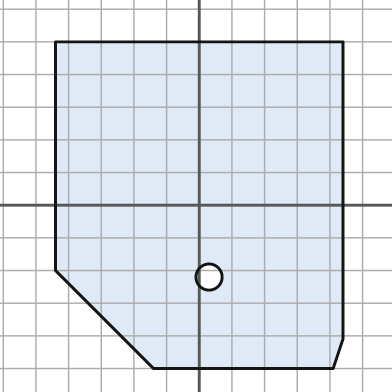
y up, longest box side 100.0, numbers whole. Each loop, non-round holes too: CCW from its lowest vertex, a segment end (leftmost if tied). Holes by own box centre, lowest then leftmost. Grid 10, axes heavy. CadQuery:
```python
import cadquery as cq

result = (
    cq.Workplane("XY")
    .moveTo(-14.0, -50.0)
    .lineTo(41.0, -50.0)
    .lineTo(44.0, -41.0)
    .lineTo(44.0, 50.0)
    .lineTo(-44.0, 50.0)
    .lineTo(-44.0, -20.0)
    .close()
    .moveTo(3.0, -22.0)
    .circle(4.0)
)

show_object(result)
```